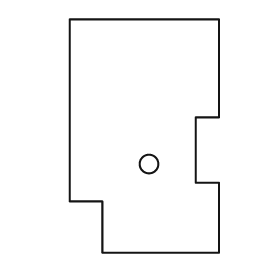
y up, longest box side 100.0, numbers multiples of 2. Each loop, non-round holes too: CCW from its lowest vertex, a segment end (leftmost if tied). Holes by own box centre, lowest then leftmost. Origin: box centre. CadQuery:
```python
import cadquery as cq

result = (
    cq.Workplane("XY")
    .moveTo(-18.0, -50.0)
    .lineTo(32.0, -50.0)
    .lineTo(32.0, -20.0)
    .lineTo(22.0, -20.0)
    .lineTo(22.0, 8.0)
    .lineTo(32.0, 8.0)
    .lineTo(32.0, 50.0)
    .lineTo(-32.0, 50.0)
    .lineTo(-32.0, -28.0)
    .lineTo(-18.0, -28.0)
    .close()
    .moveTo(2.0, -12.0)
    .circle(4.0)
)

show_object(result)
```